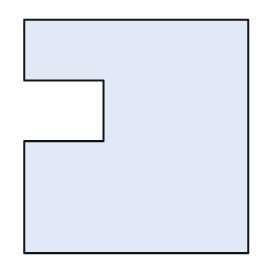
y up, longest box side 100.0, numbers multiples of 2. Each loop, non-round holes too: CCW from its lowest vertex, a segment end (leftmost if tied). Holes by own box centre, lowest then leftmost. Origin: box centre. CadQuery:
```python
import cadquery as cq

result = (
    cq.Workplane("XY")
    .moveTo(-48.0, -50.0)
    .lineTo(48.0, -50.0)
    .lineTo(48.0, 50.0)
    .lineTo(-48.0, 50.0)
    .lineTo(-48.0, 24.0)
    .lineTo(-14.0, 24.0)
    .lineTo(-14.0, -2.0)
    .lineTo(-48.0, -2.0)
    .close()
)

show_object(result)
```